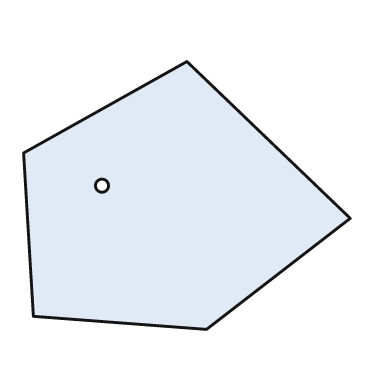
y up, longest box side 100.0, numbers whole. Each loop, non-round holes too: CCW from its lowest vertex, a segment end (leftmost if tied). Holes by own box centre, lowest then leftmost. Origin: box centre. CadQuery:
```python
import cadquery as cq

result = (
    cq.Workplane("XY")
    .moveTo(6.0, -41.0)
    .lineTo(50.0, -7.0)
    .lineTo(0.0, 41.0)
    .lineTo(-50.0, 13.0)
    .lineTo(-47.0, -37.0)
    .close()
    .moveTo(-26.0, 3.0)
    .circle(2.0)
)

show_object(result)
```